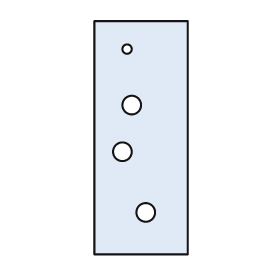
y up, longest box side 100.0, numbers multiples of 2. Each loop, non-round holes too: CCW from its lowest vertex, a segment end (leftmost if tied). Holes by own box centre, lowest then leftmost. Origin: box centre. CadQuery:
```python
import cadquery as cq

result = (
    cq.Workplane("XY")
    .moveTo(-20.0, -50.0)
    .lineTo(20.0, -50.0)
    .lineTo(20.0, 50.0)
    .lineTo(-20.0, 50.0)
    .close()
    .moveTo(2.0, -32.0)
    .circle(4.0)
    .moveTo(-8.0, -6.0)
    .circle(4.0)
    .moveTo(-4.0, 14.0)
    .circle(4.0)
    .moveTo(-6.0, 38.0)
    .circle(2.0)
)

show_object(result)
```